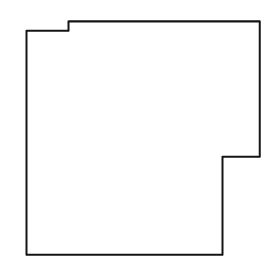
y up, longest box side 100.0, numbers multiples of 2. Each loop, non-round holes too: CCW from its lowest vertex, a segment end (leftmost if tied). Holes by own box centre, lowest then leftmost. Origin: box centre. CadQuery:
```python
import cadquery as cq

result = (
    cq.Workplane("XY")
    .moveTo(-50.0, -50.0)
    .lineTo(34.0, -50.0)
    .lineTo(34.0, -8.0)
    .lineTo(50.0, -8.0)
    .lineTo(50.0, 50.0)
    .lineTo(-32.0, 50.0)
    .lineTo(-32.0, 46.0)
    .lineTo(-50.0, 46.0)
    .close()
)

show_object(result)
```